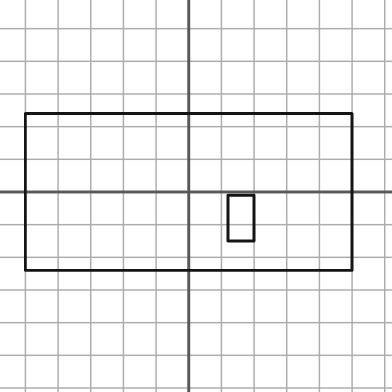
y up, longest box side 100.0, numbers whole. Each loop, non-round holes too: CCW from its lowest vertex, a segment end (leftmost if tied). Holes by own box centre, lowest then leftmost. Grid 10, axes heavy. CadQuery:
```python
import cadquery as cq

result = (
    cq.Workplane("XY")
    .moveTo(-50.0, -24.0)
    .lineTo(50.0, -24.0)
    .lineTo(50.0, 24.0)
    .lineTo(-50.0, 24.0)
    .close()
    .moveTo(12.0, -15.0)
    .lineTo(20.0, -15.0)
    .lineTo(20.0, -1.0)
    .lineTo(12.0, -1.0)
    .close()
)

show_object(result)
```